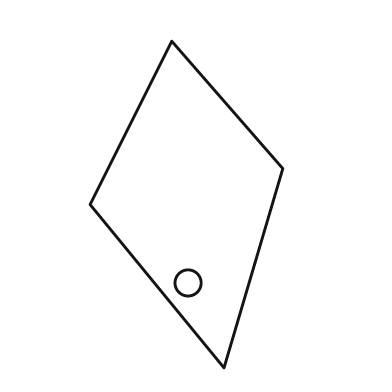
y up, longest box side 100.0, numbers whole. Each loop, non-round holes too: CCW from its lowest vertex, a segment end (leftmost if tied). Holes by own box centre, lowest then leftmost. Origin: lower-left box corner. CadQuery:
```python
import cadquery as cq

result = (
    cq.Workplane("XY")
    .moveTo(41.0, 0.0)
    .lineTo(59.0, 61.0)
    .lineTo(25.0, 100.0)
    .lineTo(0.0, 50.0)
    .close()
    .moveTo(30.0, 26.0)
    .circle(4.0)
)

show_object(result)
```